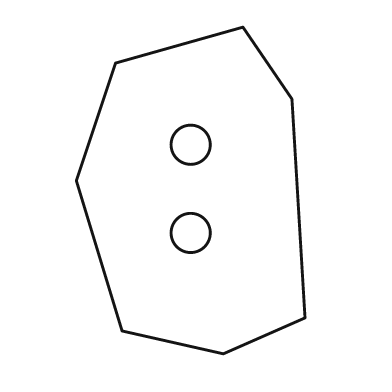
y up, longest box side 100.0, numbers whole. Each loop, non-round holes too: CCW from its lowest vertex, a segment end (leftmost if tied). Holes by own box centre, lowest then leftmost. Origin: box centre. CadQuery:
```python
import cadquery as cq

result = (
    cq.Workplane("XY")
    .moveTo(10.0, -50.0)
    .lineTo(35.0, -39.0)
    .lineTo(31.0, 28.0)
    .lineTo(16.0, 50.0)
    .lineTo(-23.0, 39.0)
    .lineTo(-35.0, 3.0)
    .lineTo(-21.0, -43.0)
    .close()
    .moveTo(0.0, -13.0)
    .circle(6.0)
    .moveTo(0.0, 14.0)
    .circle(6.0)
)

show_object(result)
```